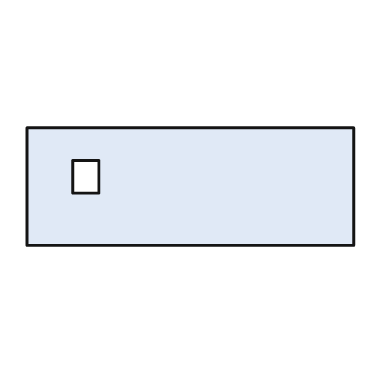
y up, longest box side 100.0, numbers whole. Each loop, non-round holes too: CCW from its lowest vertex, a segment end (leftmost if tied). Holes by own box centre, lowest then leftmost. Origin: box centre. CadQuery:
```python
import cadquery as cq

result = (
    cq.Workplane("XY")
    .moveTo(-50.0, -18.0)
    .lineTo(50.0, -18.0)
    .lineTo(50.0, 18.0)
    .lineTo(-50.0, 18.0)
    .close()
    .moveTo(-36.0, -2.0)
    .lineTo(-28.0, -2.0)
    .lineTo(-28.0, 8.0)
    .lineTo(-36.0, 8.0)
    .close()
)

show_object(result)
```